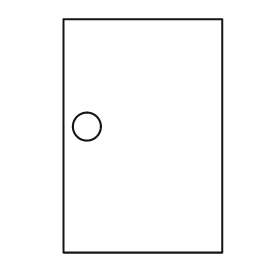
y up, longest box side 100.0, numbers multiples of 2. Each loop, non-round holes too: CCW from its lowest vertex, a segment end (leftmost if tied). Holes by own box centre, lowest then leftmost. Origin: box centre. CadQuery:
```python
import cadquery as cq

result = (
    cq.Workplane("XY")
    .moveTo(-34.0, -50.0)
    .lineTo(34.0, -50.0)
    .lineTo(34.0, 50.0)
    .lineTo(-34.0, 50.0)
    .close()
    .moveTo(-24.0, 4.0)
    .circle(6.0)
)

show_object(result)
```